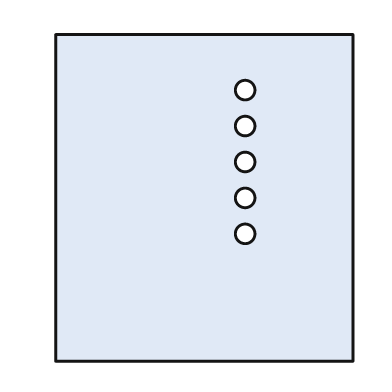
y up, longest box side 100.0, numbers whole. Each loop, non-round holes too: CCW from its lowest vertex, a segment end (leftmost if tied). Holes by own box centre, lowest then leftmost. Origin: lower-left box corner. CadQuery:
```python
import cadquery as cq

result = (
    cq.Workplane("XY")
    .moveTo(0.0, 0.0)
    .lineTo(91.0, 0.0)
    .lineTo(91.0, 100.0)
    .lineTo(0.0, 100.0)
    .close()
    .moveTo(58.0, 39.0)
    .circle(3.0)
    .moveTo(58.0, 50.0)
    .circle(3.0)
    .moveTo(58.0, 61.0)
    .circle(3.0)
    .moveTo(58.0, 72.0)
    .circle(3.0)
    .moveTo(58.0, 83.0)
    .circle(3.0)
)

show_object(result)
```